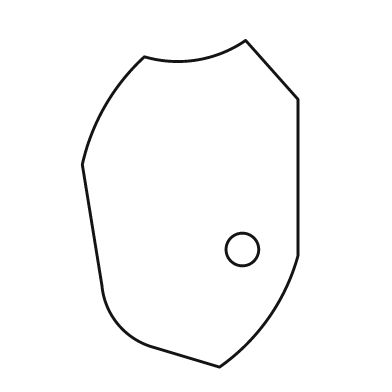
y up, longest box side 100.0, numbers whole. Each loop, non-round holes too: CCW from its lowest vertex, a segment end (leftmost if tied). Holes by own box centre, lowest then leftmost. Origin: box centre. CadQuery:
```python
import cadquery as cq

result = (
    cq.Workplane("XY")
    .moveTo(9.0, -50.0)
    .threePointArc((24.0, -35.0), (33.0, -16.0))
    .lineTo(33.0, 32.0)
    .lineTo(17.0, 50.0)
    .threePointArc((2.0, 44.0), (-14.0, 45.0))
    .threePointArc((-26.0, 30.0), (-33.0, 12.0))
    .lineTo(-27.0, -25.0)
    .threePointArc((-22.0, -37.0), (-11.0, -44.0))
    .close()
    .moveTo(16.0, -14.0)
    .circle(5.0)
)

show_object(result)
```